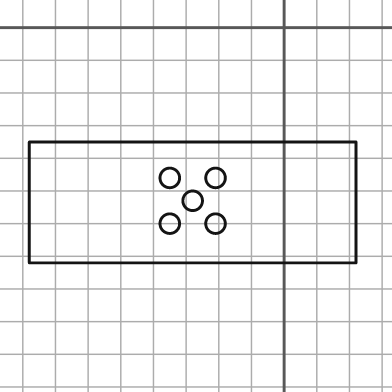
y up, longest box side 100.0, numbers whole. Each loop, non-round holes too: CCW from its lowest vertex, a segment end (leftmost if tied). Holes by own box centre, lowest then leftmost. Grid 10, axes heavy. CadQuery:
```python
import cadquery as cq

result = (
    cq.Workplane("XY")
    .moveTo(-78.0, -72.0)
    .lineTo(22.0, -72.0)
    .lineTo(22.0, -35.0)
    .lineTo(-78.0, -35.0)
    .close()
    .moveTo(-35.0, -60.0)
    .circle(3.0)
    .moveTo(-21.0, -60.0)
    .circle(3.0)
    .moveTo(-28.0, -53.0)
    .circle(3.0)
    .moveTo(-35.0, -46.0)
    .circle(3.0)
    .moveTo(-21.0, -46.0)
    .circle(3.0)
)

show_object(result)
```